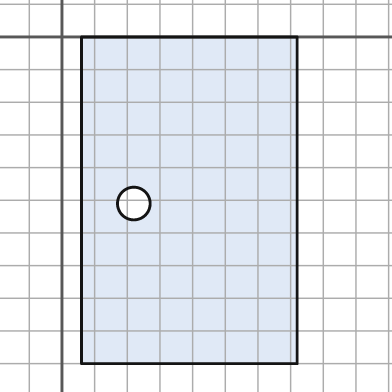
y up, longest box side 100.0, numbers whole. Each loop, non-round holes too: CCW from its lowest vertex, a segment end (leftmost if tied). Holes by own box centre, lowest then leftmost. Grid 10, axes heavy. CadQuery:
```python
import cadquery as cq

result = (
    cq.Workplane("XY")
    .moveTo(6.0, -100.0)
    .lineTo(72.0, -100.0)
    .lineTo(72.0, 0.0)
    .lineTo(6.0, 0.0)
    .close()
    .moveTo(22.0, -51.0)
    .circle(5.0)
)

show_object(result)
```